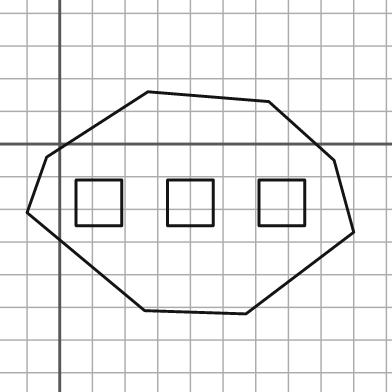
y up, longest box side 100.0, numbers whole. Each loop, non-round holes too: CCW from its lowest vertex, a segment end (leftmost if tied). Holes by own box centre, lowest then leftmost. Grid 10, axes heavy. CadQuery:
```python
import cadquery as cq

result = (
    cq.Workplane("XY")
    .moveTo(57.0, -52.0)
    .lineTo(90.0, -27.0)
    .lineTo(84.0, -5.0)
    .lineTo(64.0, 13.0)
    .lineTo(27.0, 16.0)
    .lineTo(-4.0, -4.0)
    .lineTo(-10.0, -21.0)
    .lineTo(26.0, -51.0)
    .close()
    .moveTo(5.0, -25.0)
    .lineTo(19.0, -25.0)
    .lineTo(19.0, -11.0)
    .lineTo(5.0, -11.0)
    .close()
    .moveTo(33.0, -25.0)
    .lineTo(47.0, -25.0)
    .lineTo(47.0, -11.0)
    .lineTo(33.0, -11.0)
    .close()
    .moveTo(61.0, -25.0)
    .lineTo(75.0, -25.0)
    .lineTo(75.0, -11.0)
    .lineTo(61.0, -11.0)
    .close()
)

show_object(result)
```